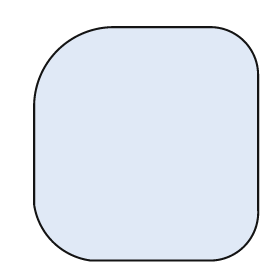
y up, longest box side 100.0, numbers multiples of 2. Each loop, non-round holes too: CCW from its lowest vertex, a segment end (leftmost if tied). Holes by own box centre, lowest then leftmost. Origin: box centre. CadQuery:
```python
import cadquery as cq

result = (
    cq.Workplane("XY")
    .moveTo(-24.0, -50.0)
    .lineTo(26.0, -50.0)
    .threePointArc((42.0, -44.0), (48.0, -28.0))
    .lineTo(48.0, 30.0)
    .threePointArc((42.0, 44.0), (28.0, 50.0))
    .lineTo(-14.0, 50.0)
    .threePointArc((-38.0, 40.0), (-48.0, 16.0))
    .lineTo(-48.0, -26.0)
    .threePointArc((-40.0, -42.0), (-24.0, -50.0))
    .close()
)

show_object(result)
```